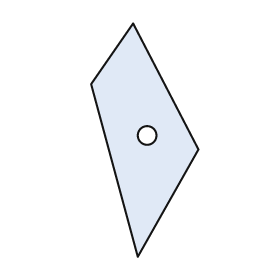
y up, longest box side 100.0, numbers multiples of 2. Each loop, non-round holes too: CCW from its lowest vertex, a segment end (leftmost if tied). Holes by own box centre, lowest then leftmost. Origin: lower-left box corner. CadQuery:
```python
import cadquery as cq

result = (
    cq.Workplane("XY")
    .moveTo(20.0, 0.0)
    .lineTo(46.0, 46.0)
    .lineTo(18.0, 100.0)
    .lineTo(0.0, 74.0)
    .close()
    .moveTo(24.0, 52.0)
    .circle(4.0)
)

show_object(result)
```